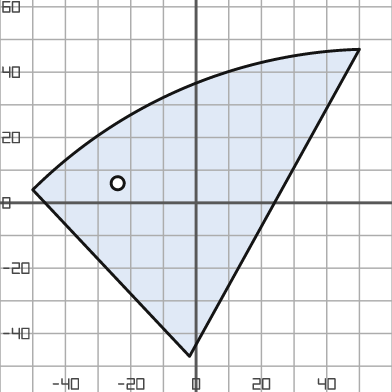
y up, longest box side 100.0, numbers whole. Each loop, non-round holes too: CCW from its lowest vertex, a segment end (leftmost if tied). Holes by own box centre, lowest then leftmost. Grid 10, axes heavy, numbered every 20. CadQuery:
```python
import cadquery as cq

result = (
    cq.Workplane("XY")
    .moveTo(-2.0, -47.0)
    .lineTo(50.0, 47.0)
    .threePointArc((-4.0, 35.0), (-50.0, 4.0))
    .close()
    .moveTo(-24.0, 6.0)
    .circle(2.0)
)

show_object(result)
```